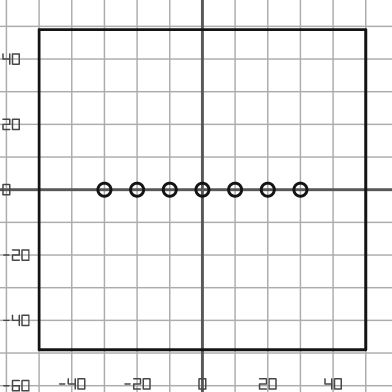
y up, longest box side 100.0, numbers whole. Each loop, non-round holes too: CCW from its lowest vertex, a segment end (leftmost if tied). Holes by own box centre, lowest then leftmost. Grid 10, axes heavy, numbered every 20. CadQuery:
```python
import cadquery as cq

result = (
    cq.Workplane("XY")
    .moveTo(-50.0, -49.0)
    .lineTo(50.0, -49.0)
    .lineTo(50.0, 49.0)
    .lineTo(-50.0, 49.0)
    .close()
    .moveTo(-30.0, 0.0)
    .circle(2.0)
    .moveTo(-20.0, 0.0)
    .circle(2.0)
    .moveTo(-10.0, 0.0)
    .circle(2.0)
    .moveTo(0.0, 0.0)
    .circle(2.0)
    .moveTo(10.0, 0.0)
    .circle(2.0)
    .moveTo(20.0, 0.0)
    .circle(2.0)
    .moveTo(30.0, 0.0)
    .circle(2.0)
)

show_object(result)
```